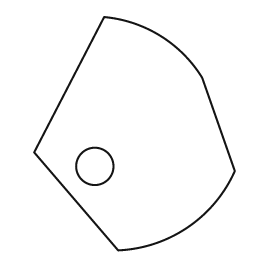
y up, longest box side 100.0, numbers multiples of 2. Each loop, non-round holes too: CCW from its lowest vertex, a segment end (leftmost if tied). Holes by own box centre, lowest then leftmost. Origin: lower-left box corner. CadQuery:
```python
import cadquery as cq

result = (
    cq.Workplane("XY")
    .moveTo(36.0, 0.0)
    .threePointArc((66.0, 10.0), (86.0, 34.0))
    .lineTo(72.0, 74.0)
    .threePointArc((54.0, 92.0), (30.0, 100.0))
    .lineTo(0.0, 42.0)
    .close()
    .moveTo(26.0, 36.0)
    .circle(8.0)
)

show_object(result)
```